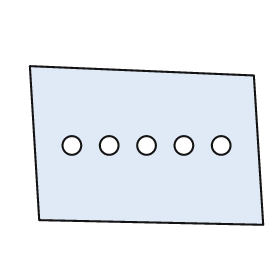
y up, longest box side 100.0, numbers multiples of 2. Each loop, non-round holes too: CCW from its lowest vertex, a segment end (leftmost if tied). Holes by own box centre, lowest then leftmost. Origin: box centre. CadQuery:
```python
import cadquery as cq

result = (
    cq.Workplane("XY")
    .moveTo(50.0, -34.0)
    .lineTo(46.0, 30.0)
    .lineTo(-50.0, 34.0)
    .lineTo(-46.0, -32.0)
    .close()
    .moveTo(-32.0, 0.0)
    .circle(4.0)
    .moveTo(-16.0, 0.0)
    .circle(4.0)
    .moveTo(0.0, 0.0)
    .circle(4.0)
    .moveTo(16.0, 0.0)
    .circle(4.0)
    .moveTo(32.0, 0.0)
    .circle(4.0)
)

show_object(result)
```